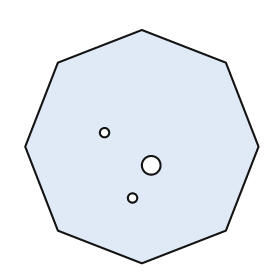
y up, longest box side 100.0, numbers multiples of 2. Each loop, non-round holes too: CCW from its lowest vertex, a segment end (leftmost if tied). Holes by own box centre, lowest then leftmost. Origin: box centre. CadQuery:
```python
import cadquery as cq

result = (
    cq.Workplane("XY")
    .moveTo(0.0, -50.0)
    .lineTo(36.0, -36.0)
    .lineTo(50.0, 0.0)
    .lineTo(36.0, 36.0)
    .lineTo(0.0, 50.0)
    .lineTo(-36.0, 36.0)
    .lineTo(-50.0, 0.0)
    .lineTo(-36.0, -36.0)
    .close()
    .moveTo(-4.0, -22.0)
    .circle(2.0)
    .moveTo(4.0, -8.0)
    .circle(4.0)
    .moveTo(-16.0, 6.0)
    .circle(2.0)
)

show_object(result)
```